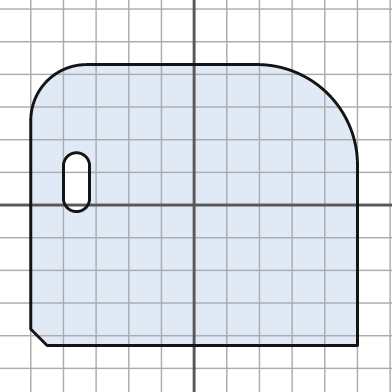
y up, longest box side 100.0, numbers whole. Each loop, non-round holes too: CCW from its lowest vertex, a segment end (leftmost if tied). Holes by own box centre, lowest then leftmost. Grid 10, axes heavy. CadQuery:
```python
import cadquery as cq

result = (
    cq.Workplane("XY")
    .moveTo(-45.0, -43.0)
    .lineTo(50.0, -43.0)
    .lineTo(50.0, 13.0)
    .threePointArc((41.0, 34.0), (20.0, 43.0))
    .lineTo(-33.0, 43.0)
    .threePointArc((-45.0, 38.0), (-50.0, 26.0))
    .lineTo(-50.0, -38.0)
    .close()
    .moveTo(-40.0, 2.0)
    .threePointArc((-36.0, -2.0), (-32.0, 2.0))
    .lineTo(-32.0, 12.0)
    .threePointArc((-36.0, 16.0), (-40.0, 12.0))
    .close()
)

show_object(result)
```